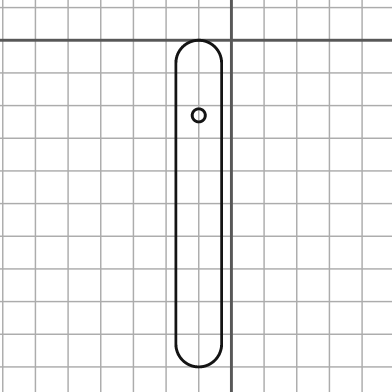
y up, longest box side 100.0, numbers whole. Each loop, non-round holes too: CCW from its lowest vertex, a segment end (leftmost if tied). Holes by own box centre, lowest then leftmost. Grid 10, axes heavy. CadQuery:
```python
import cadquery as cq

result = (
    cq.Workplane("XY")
    .moveTo(-17.0, -93.0)
    .threePointArc((-10.0, -100.0), (-3.0, -93.0))
    .lineTo(-3.0, -7.0)
    .threePointArc((-10.0, 0.0), (-17.0, -7.0))
    .close()
    .moveTo(-10.0, -23.0)
    .circle(2.0)
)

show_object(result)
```